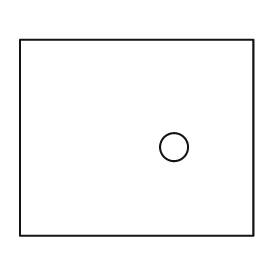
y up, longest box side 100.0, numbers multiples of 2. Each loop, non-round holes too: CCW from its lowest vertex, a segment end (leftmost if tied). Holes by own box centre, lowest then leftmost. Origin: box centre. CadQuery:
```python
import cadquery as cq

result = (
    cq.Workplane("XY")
    .moveTo(-50.0, -42.0)
    .lineTo(50.0, -42.0)
    .lineTo(50.0, 42.0)
    .lineTo(-50.0, 42.0)
    .close()
    .moveTo(16.0, -4.0)
    .circle(6.0)
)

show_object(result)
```